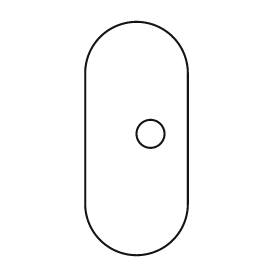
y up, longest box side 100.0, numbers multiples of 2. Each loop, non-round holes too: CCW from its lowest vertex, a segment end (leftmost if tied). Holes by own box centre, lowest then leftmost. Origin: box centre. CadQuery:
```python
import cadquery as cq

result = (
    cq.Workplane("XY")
    .moveTo(-22.0, -28.0)
    .threePointArc((0.0, -50.0), (22.0, -28.0))
    .lineTo(22.0, 28.0)
    .threePointArc((0.0, 50.0), (-22.0, 28.0))
    .close()
    .moveTo(6.0, 2.0)
    .circle(6.0)
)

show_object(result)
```